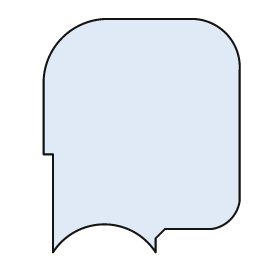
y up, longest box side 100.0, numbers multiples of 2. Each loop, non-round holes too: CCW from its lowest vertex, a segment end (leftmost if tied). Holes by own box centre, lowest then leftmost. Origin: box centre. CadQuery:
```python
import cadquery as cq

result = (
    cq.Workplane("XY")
    .moveTo(-38.0, -50.0)
    .threePointArc((-16.0, -38.0), (6.0, -50.0))
    .lineTo(6.0, -44.0)
    .lineTo(10.0, -40.0)
    .lineTo(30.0, -40.0)
    .threePointArc((38.0, -36.0), (42.0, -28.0))
    .lineTo(42.0, 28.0)
    .threePointArc((36.0, 44.0), (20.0, 50.0))
    .lineTo(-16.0, 50.0)
    .threePointArc((-34.0, 42.0), (-42.0, 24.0))
    .lineTo(-42.0, -8.0)
    .lineTo(-38.0, -8.0)
    .close()
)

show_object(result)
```